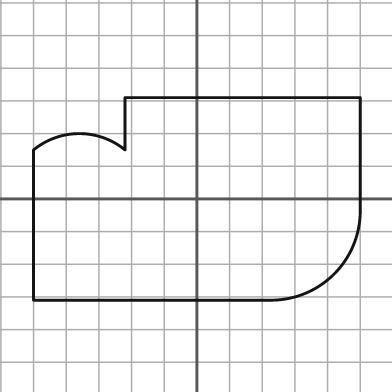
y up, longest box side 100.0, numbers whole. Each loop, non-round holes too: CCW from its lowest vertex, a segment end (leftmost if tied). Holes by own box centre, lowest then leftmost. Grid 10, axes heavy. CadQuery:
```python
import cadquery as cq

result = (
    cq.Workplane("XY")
    .moveTo(-50.0, -31.0)
    .lineTo(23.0, -31.0)
    .threePointArc((42.0, -23.0), (50.0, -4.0))
    .lineTo(50.0, 31.0)
    .lineTo(-22.0, 31.0)
    .lineTo(-22.0, 15.0)
    .threePointArc((-36.0, 20.0), (-50.0, 15.0))
    .close()
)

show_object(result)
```